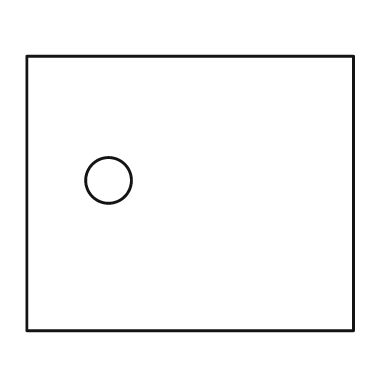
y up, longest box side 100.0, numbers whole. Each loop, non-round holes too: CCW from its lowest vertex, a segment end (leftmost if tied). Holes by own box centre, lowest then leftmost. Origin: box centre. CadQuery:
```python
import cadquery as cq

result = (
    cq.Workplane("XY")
    .moveTo(-50.0, -42.0)
    .lineTo(50.0, -42.0)
    .lineTo(50.0, 42.0)
    .lineTo(-50.0, 42.0)
    .close()
    .moveTo(-25.0, 4.0)
    .circle(7.0)
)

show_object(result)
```